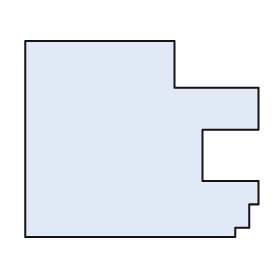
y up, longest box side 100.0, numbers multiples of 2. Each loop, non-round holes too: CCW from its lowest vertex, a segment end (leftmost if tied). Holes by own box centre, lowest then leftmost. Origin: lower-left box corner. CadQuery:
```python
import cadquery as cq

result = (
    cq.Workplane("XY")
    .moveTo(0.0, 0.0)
    .lineTo(90.0, 0.0)
    .lineTo(90.0, 4.0)
    .lineTo(96.0, 4.0)
    .lineTo(96.0, 14.0)
    .lineTo(100.0, 14.0)
    .lineTo(100.0, 24.0)
    .lineTo(76.0, 24.0)
    .lineTo(76.0, 46.0)
    .lineTo(100.0, 46.0)
    .lineTo(100.0, 64.0)
    .lineTo(64.0, 64.0)
    .lineTo(64.0, 84.0)
    .lineTo(0.0, 84.0)
    .close()
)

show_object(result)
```